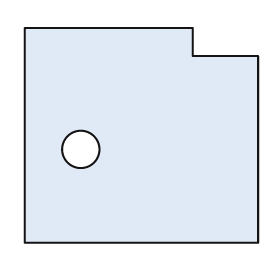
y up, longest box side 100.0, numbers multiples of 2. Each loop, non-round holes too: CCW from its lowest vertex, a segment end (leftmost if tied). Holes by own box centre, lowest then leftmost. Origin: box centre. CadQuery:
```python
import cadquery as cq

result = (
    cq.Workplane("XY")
    .moveTo(-50.0, -46.0)
    .lineTo(50.0, -46.0)
    .lineTo(50.0, 34.0)
    .lineTo(22.0, 34.0)
    .lineTo(22.0, 46.0)
    .lineTo(-50.0, 46.0)
    .close()
    .moveTo(-26.0, -6.0)
    .circle(8.0)
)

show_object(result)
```